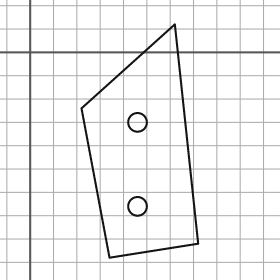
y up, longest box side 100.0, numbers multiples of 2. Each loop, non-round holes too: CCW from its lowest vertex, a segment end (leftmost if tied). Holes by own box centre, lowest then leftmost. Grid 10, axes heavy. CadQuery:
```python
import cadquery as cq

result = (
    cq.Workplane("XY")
    .moveTo(34.0, -88.0)
    .lineTo(72.0, -82.0)
    .lineTo(62.0, 12.0)
    .lineTo(22.0, -24.0)
    .close()
    .moveTo(46.0, -66.0)
    .circle(4.0)
    .moveTo(46.0, -30.0)
    .circle(4.0)
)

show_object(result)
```